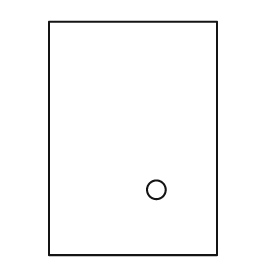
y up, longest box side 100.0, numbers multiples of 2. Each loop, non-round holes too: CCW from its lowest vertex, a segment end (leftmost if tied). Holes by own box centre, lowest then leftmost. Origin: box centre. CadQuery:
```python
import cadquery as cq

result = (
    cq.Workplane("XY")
    .moveTo(-36.0, -50.0)
    .lineTo(36.0, -50.0)
    .lineTo(36.0, 50.0)
    .lineTo(-36.0, 50.0)
    .close()
    .moveTo(10.0, -22.0)
    .circle(4.0)
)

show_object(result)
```